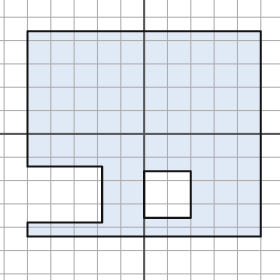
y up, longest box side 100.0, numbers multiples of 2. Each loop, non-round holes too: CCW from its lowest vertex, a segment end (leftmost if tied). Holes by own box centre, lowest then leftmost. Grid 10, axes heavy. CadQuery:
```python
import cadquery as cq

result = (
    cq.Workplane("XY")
    .moveTo(-50.0, -44.0)
    .lineTo(50.0, -44.0)
    .lineTo(50.0, 44.0)
    .lineTo(-50.0, 44.0)
    .lineTo(-50.0, -14.0)
    .lineTo(-18.0, -14.0)
    .lineTo(-18.0, -38.0)
    .lineTo(-50.0, -38.0)
    .close()
    .moveTo(0.0, -36.0)
    .lineTo(20.0, -36.0)
    .lineTo(20.0, -16.0)
    .lineTo(0.0, -16.0)
    .close()
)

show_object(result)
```